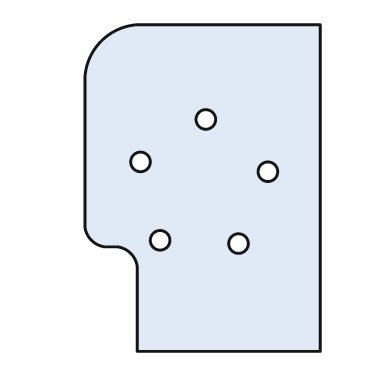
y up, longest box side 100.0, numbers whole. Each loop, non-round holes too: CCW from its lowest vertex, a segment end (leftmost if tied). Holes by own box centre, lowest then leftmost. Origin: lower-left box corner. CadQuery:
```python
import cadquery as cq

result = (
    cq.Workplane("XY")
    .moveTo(16.0, 0.0)
    .lineTo(72.0, 0.0)
    .lineTo(72.0, 100.0)
    .lineTo(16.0, 100.0)
    .threePointArc((5.0, 95.0), (0.0, 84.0))
    .lineTo(0.0, 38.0)
    .threePointArc((2.0, 34.0), (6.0, 32.0))
    .lineTo(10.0, 32.0)
    .threePointArc((14.0, 30.0), (16.0, 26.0))
    .close()
    .moveTo(47.0, 33.0)
    .circle(3.0)
    .moveTo(23.0, 34.0)
    .circle(3.0)
    .moveTo(56.0, 55.0)
    .circle(3.0)
    .moveTo(17.0, 58.0)
    .circle(3.0)
    .moveTo(37.0, 71.0)
    .circle(3.0)
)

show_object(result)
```